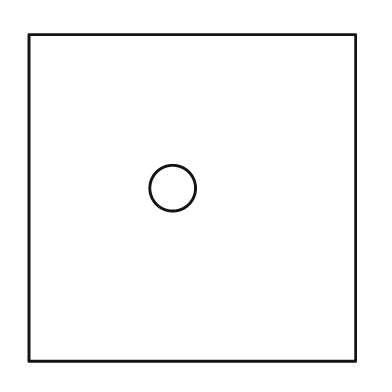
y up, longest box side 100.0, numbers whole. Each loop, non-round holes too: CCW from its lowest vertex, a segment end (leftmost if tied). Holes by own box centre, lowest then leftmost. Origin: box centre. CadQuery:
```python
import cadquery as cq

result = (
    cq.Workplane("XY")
    .moveTo(-50.0, -50.0)
    .lineTo(50.0, -50.0)
    .lineTo(50.0, 50.0)
    .lineTo(-50.0, 50.0)
    .close()
    .moveTo(-6.0, 3.0)
    .circle(7.0)
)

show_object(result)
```